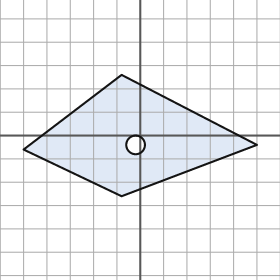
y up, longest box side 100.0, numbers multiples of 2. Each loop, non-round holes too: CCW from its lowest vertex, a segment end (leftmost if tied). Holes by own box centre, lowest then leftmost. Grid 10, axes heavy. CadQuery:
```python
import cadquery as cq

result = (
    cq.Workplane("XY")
    .moveTo(-8.0, -26.0)
    .lineTo(50.0, -4.0)
    .lineTo(-8.0, 26.0)
    .lineTo(-50.0, -6.0)
    .close()
    .moveTo(-2.0, -4.0)
    .circle(4.0)
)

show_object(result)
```